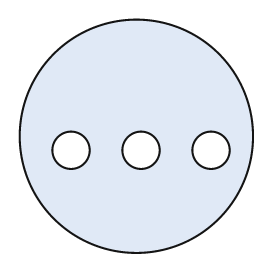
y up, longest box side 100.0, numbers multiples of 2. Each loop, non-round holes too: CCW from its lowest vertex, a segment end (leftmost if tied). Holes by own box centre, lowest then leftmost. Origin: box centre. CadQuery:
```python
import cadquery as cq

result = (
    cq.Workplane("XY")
    .moveTo(0.0, 0.0)
    .circle(50.0)
    .moveTo(-28.0, -6.0)
    .circle(8.0)
    .moveTo(2.0, -6.0)
    .circle(8.0)
    .moveTo(32.0, -6.0)
    .circle(8.0)
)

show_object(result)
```